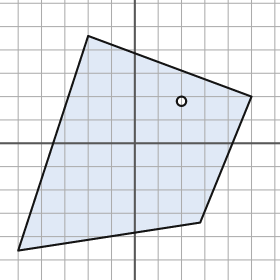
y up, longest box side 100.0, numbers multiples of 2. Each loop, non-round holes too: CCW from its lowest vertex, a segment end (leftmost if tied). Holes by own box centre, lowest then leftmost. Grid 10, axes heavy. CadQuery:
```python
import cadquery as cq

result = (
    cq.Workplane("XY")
    .moveTo(-50.0, -46.0)
    .lineTo(28.0, -34.0)
    .lineTo(50.0, 20.0)
    .lineTo(-20.0, 46.0)
    .close()
    .moveTo(20.0, 18.0)
    .circle(2.0)
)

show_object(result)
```